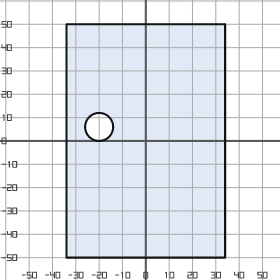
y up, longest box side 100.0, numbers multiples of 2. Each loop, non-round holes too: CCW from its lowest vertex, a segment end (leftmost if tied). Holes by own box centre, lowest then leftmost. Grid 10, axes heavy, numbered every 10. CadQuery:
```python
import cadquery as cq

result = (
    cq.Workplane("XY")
    .moveTo(-34.0, -50.0)
    .lineTo(34.0, -50.0)
    .lineTo(34.0, 50.0)
    .lineTo(-34.0, 50.0)
    .close()
    .moveTo(-20.0, 6.0)
    .circle(6.0)
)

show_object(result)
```